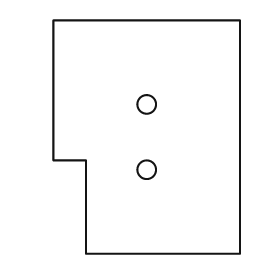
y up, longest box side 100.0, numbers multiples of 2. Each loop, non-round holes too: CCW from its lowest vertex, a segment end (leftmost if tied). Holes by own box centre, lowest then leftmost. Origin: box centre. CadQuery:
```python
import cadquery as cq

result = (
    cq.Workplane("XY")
    .moveTo(-26.0, -50.0)
    .lineTo(40.0, -50.0)
    .lineTo(40.0, 50.0)
    .lineTo(-40.0, 50.0)
    .lineTo(-40.0, -10.0)
    .lineTo(-26.0, -10.0)
    .close()
    .moveTo(0.0, -14.0)
    .circle(4.0)
    .moveTo(0.0, 14.0)
    .circle(4.0)
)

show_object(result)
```